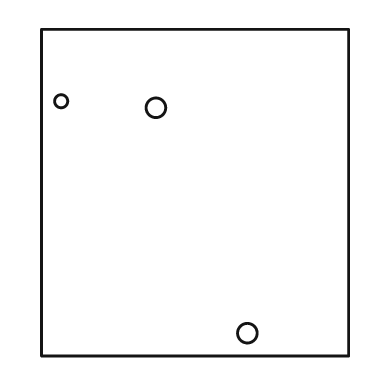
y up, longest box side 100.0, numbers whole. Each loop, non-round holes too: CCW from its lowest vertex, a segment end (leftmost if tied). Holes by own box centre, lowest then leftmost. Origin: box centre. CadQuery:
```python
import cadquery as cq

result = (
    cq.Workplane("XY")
    .moveTo(-47.0, -50.0)
    .lineTo(47.0, -50.0)
    .lineTo(47.0, 50.0)
    .lineTo(-47.0, 50.0)
    .close()
    .moveTo(16.0, -43.0)
    .circle(3.0)
    .moveTo(-12.0, 26.0)
    .circle(3.0)
    .moveTo(-41.0, 28.0)
    .circle(2.0)
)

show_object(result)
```